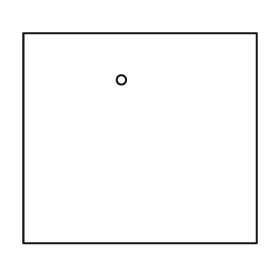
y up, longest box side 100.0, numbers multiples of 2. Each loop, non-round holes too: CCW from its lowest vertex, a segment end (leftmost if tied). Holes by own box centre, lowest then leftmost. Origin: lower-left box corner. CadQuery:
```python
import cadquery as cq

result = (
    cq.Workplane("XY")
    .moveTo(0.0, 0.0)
    .lineTo(100.0, 0.0)
    .lineTo(100.0, 90.0)
    .lineTo(0.0, 90.0)
    .close()
    .moveTo(42.0, 70.0)
    .circle(2.0)
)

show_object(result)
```